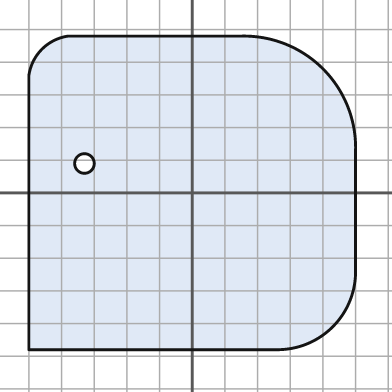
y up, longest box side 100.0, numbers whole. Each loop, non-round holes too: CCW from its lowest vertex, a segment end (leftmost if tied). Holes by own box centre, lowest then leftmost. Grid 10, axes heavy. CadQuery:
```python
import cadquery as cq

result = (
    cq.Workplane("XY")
    .moveTo(-50.0, -48.0)
    .lineTo(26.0, -48.0)
    .threePointArc((43.0, -41.0), (50.0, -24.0))
    .lineTo(50.0, 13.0)
    .threePointArc((40.0, 38.0), (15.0, 48.0))
    .lineTo(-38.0, 48.0)
    .threePointArc((-46.0, 44.0), (-50.0, 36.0))
    .close()
    .moveTo(-33.0, 9.0)
    .circle(3.0)
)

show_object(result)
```